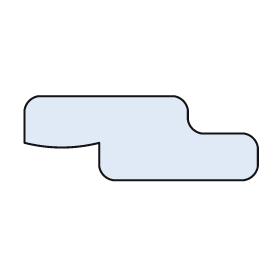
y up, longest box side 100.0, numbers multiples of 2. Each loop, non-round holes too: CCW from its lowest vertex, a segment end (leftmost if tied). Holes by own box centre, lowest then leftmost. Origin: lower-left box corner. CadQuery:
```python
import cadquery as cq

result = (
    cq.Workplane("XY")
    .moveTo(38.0, 0.0)
    .lineTo(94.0, 0.0)
    .threePointArc((98.0, 2.0), (100.0, 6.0))
    .lineTo(100.0, 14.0)
    .threePointArc((98.0, 18.0), (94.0, 20.0))
    .lineTo(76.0, 20.0)
    .threePointArc((72.0, 22.0), (70.0, 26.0))
    .lineTo(70.0, 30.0)
    .threePointArc((68.0, 34.0), (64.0, 36.0))
    .lineTo(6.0, 36.0)
    .threePointArc((2.0, 34.0), (0.0, 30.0))
    .lineTo(0.0, 16.0)
    .threePointArc((16.0, 14.0), (32.0, 16.0))
    .lineTo(32.0, 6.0)
    .threePointArc((34.0, 2.0), (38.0, 0.0))
    .close()
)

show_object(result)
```